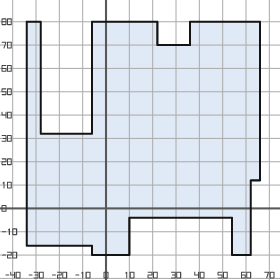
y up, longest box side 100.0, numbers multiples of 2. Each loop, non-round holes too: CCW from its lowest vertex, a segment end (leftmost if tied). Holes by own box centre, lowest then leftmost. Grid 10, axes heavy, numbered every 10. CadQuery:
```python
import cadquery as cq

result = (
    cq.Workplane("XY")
    .moveTo(-6.0, -20.0)
    .lineTo(10.0, -20.0)
    .lineTo(10.0, -4.0)
    .lineTo(54.0, -4.0)
    .lineTo(54.0, -20.0)
    .lineTo(62.0, -20.0)
    .lineTo(62.0, 12.0)
    .lineTo(66.0, 12.0)
    .lineTo(66.0, 80.0)
    .lineTo(36.0, 80.0)
    .lineTo(36.0, 70.0)
    .lineTo(22.0, 70.0)
    .lineTo(22.0, 80.0)
    .lineTo(-6.0, 80.0)
    .lineTo(-6.0, 32.0)
    .lineTo(-28.0, 32.0)
    .lineTo(-28.0, 80.0)
    .lineTo(-34.0, 80.0)
    .lineTo(-34.0, -16.0)
    .lineTo(-6.0, -16.0)
    .close()
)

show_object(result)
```